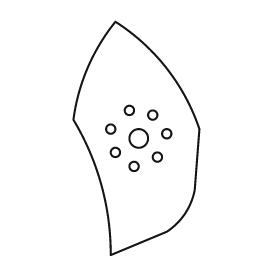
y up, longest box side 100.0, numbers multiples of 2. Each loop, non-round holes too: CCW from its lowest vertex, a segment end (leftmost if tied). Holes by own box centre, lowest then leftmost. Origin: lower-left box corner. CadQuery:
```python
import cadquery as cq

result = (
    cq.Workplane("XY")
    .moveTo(16.0, 0.0)
    .lineTo(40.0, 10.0)
    .threePointArc((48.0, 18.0), (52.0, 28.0))
    .lineTo(54.0, 54.0)
    .threePointArc((40.0, 80.0), (18.0, 100.0))
    .threePointArc((6.0, 80.0), (0.0, 58.0))
    .threePointArc((12.0, 30.0), (16.0, 0.0))
    .close()
    .moveTo(26.0, 38.0)
    .circle(2.0)
    .moveTo(36.0, 42.0)
    .circle(2.0)
    .moveTo(18.0, 44.0)
    .circle(2.0)
    .moveTo(28.0, 50.0)
    .circle(4.0)
    .moveTo(40.0, 52.0)
    .circle(2.0)
    .moveTo(16.0, 54.0)
    .circle(2.0)
    .moveTo(34.0, 60.0)
    .circle(2.0)
    .moveTo(24.0, 62.0)
    .circle(2.0)
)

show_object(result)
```